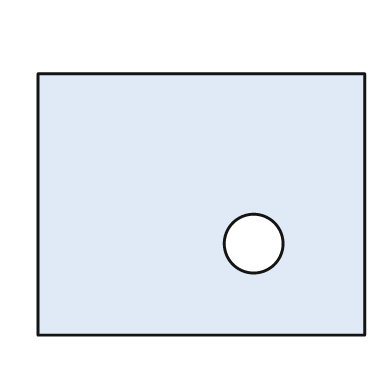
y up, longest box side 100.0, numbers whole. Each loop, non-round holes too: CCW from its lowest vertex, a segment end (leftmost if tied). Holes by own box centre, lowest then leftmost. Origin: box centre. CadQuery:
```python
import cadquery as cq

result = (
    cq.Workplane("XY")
    .moveTo(-50.0, -40.0)
    .lineTo(50.0, -40.0)
    .lineTo(50.0, 40.0)
    .lineTo(-50.0, 40.0)
    .close()
    .moveTo(16.0, -12.0)
    .circle(9.0)
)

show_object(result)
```